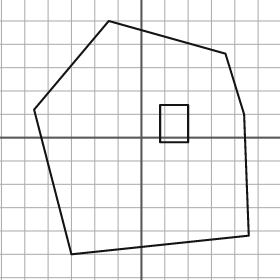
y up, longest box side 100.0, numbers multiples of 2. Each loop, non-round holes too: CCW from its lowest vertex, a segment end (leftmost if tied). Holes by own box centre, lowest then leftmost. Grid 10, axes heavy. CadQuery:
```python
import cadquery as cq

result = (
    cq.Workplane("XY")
    .moveTo(-30.0, -50.0)
    .lineTo(46.0, -42.0)
    .lineTo(44.0, 10.0)
    .lineTo(36.0, 36.0)
    .lineTo(-14.0, 50.0)
    .lineTo(-46.0, 12.0)
    .close()
    .moveTo(8.0, -2.0)
    .lineTo(20.0, -2.0)
    .lineTo(20.0, 14.0)
    .lineTo(8.0, 14.0)
    .close()
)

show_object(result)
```